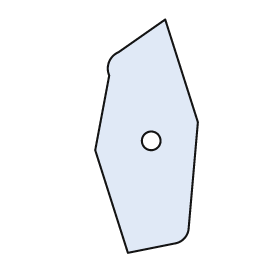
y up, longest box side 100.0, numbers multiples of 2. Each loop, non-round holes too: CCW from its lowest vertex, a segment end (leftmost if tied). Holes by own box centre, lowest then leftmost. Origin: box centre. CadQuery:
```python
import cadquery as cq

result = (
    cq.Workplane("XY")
    .moveTo(-8.0, -50.0)
    .lineTo(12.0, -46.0)
    .threePointArc((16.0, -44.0), (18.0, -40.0))
    .lineTo(22.0, 6.0)
    .lineTo(8.0, 50.0)
    .lineTo(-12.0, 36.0)
    .threePointArc((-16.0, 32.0), (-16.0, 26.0))
    .lineTo(-22.0, -6.0)
    .close()
    .moveTo(2.0, -2.0)
    .circle(4.0)
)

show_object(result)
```